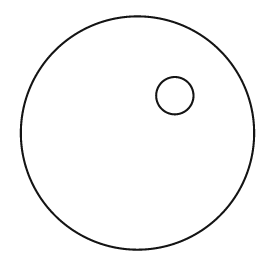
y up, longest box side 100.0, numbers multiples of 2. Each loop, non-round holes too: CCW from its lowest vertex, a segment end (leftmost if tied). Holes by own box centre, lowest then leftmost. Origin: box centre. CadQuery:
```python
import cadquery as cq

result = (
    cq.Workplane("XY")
    .moveTo(0.0, 0.0)
    .circle(50.0)
    .moveTo(16.0, 16.0)
    .circle(8.0)
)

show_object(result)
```